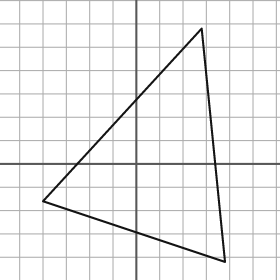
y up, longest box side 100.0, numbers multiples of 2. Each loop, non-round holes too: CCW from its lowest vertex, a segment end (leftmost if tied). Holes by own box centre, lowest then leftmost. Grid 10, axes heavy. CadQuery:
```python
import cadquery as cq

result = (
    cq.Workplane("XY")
    .moveTo(38.0, -42.0)
    .lineTo(28.0, 58.0)
    .lineTo(-40.0, -16.0)
    .close()
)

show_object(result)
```